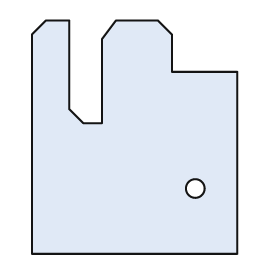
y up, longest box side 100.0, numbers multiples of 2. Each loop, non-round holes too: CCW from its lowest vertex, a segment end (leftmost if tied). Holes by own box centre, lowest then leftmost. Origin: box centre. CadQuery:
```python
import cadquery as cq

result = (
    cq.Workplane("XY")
    .moveTo(-44.0, -50.0)
    .lineTo(44.0, -50.0)
    .lineTo(44.0, 28.0)
    .lineTo(16.0, 28.0)
    .lineTo(16.0, 44.0)
    .lineTo(10.0, 50.0)
    .lineTo(-8.0, 50.0)
    .lineTo(-14.0, 42.0)
    .lineTo(-14.0, 6.0)
    .lineTo(-22.0, 6.0)
    .lineTo(-28.0, 12.0)
    .lineTo(-28.0, 50.0)
    .lineTo(-38.0, 50.0)
    .lineTo(-44.0, 44.0)
    .close()
    .moveTo(26.0, -22.0)
    .circle(4.0)
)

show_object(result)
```